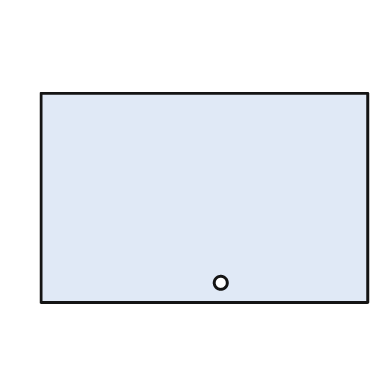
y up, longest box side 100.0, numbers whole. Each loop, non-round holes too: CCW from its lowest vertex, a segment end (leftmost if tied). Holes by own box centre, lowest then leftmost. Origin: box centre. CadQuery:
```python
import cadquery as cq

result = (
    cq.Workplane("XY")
    .moveTo(-50.0, -32.0)
    .lineTo(50.0, -32.0)
    .lineTo(50.0, 32.0)
    .lineTo(-50.0, 32.0)
    .close()
    .moveTo(5.0, -26.0)
    .circle(2.0)
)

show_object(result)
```